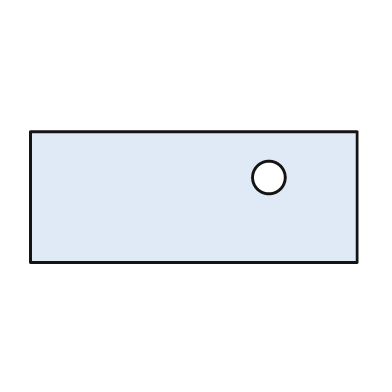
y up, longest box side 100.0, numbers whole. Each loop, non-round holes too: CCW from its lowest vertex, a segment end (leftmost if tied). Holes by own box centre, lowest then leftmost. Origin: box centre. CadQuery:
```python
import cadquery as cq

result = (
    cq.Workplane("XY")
    .moveTo(-50.0, -20.0)
    .lineTo(50.0, -20.0)
    .lineTo(50.0, 20.0)
    .lineTo(-50.0, 20.0)
    .close()
    .moveTo(23.0, 6.0)
    .circle(5.0)
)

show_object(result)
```